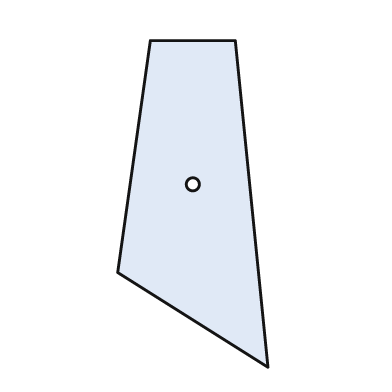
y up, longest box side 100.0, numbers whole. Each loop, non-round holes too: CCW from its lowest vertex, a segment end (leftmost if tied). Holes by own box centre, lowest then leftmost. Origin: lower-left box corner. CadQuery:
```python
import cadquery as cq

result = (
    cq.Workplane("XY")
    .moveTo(46.0, 0.0)
    .lineTo(36.0, 100.0)
    .lineTo(10.0, 100.0)
    .lineTo(0.0, 29.0)
    .close()
    .moveTo(23.0, 56.0)
    .circle(2.0)
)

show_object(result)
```